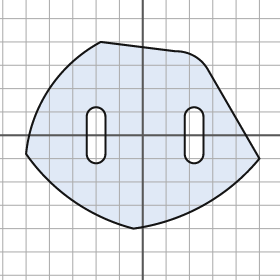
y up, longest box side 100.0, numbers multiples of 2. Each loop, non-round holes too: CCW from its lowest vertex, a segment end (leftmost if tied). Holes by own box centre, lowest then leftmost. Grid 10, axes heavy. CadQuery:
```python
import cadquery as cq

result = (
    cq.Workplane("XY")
    .moveTo(-4.0, -40.0)
    .threePointArc((26.0, -30.0), (50.0, -10.0))
    .lineTo(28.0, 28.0)
    .threePointArc((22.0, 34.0), (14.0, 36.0))
    .lineTo(-18.0, 40.0)
    .threePointArc((-40.0, 20.0), (-50.0, -8.0))
    .threePointArc((-30.0, -28.0), (-4.0, -40.0))
    .close()
    .moveTo(-24.0, -8.0)
    .threePointArc((-20.0, -12.0), (-16.0, -8.0))
    .lineTo(-16.0, 8.0)
    .threePointArc((-20.0, 12.0), (-24.0, 8.0))
    .close()
    .moveTo(18.0, -8.0)
    .threePointArc((22.0, -12.0), (26.0, -8.0))
    .lineTo(26.0, 8.0)
    .threePointArc((22.0, 12.0), (18.0, 8.0))
    .close()
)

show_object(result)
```